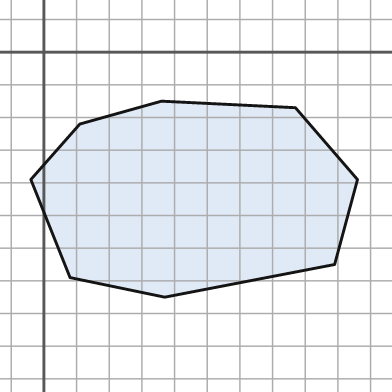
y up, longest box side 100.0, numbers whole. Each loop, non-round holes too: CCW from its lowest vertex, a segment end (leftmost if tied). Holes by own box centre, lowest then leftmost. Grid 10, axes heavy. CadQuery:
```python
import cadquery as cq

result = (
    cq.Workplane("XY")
    .moveTo(37.0, -75.0)
    .lineTo(89.0, -65.0)
    .lineTo(96.0, -39.0)
    .lineTo(77.0, -17.0)
    .lineTo(36.0, -15.0)
    .lineTo(11.0, -22.0)
    .lineTo(-4.0, -39.0)
    .lineTo(8.0, -69.0)
    .close()
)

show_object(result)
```